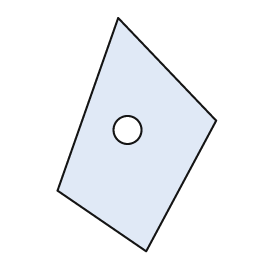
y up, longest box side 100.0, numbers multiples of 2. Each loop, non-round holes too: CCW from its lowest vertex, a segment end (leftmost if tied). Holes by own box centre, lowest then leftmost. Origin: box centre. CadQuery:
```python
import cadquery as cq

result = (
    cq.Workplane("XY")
    .moveTo(4.0, -50.0)
    .lineTo(34.0, 6.0)
    .lineTo(-8.0, 50.0)
    .lineTo(-34.0, -24.0)
    .close()
    .moveTo(-4.0, 2.0)
    .circle(6.0)
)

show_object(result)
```